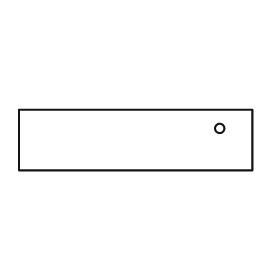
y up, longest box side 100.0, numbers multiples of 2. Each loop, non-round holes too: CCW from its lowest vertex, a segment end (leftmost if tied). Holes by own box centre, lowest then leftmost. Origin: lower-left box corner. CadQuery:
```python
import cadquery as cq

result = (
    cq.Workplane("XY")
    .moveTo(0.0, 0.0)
    .lineTo(100.0, 0.0)
    .lineTo(100.0, 26.0)
    .lineTo(0.0, 26.0)
    .close()
    .moveTo(86.0, 18.0)
    .circle(2.0)
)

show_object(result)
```